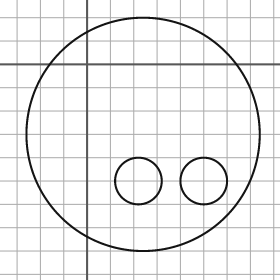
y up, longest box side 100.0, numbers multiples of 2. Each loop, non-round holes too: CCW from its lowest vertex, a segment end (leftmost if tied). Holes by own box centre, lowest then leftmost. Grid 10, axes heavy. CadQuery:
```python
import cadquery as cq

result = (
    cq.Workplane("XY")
    .moveTo(24.0, -30.0)
    .circle(50.0)
    .moveTo(22.0, -50.0)
    .circle(10.0)
    .moveTo(50.0, -50.0)
    .circle(10.0)
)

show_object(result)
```